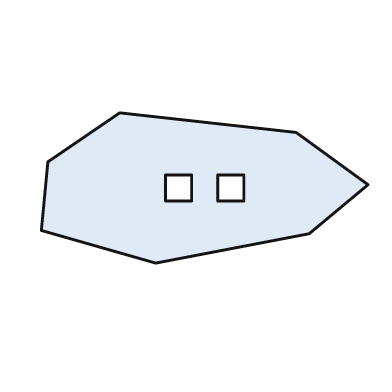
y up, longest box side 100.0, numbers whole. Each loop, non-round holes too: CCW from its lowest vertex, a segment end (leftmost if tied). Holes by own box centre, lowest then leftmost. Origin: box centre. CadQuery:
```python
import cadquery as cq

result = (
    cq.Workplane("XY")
    .moveTo(-15.0, -23.0)
    .lineTo(32.0, -14.0)
    .lineTo(50.0, 1.0)
    .lineTo(28.0, 17.0)
    .lineTo(-26.0, 23.0)
    .lineTo(-48.0, 8.0)
    .lineTo(-50.0, -13.0)
    .close()
    .moveTo(-12.0, -4.0)
    .lineTo(-4.0, -4.0)
    .lineTo(-4.0, 4.0)
    .lineTo(-12.0, 4.0)
    .close()
    .moveTo(4.0, -4.0)
    .lineTo(12.0, -4.0)
    .lineTo(12.0, 4.0)
    .lineTo(4.0, 4.0)
    .close()
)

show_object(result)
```